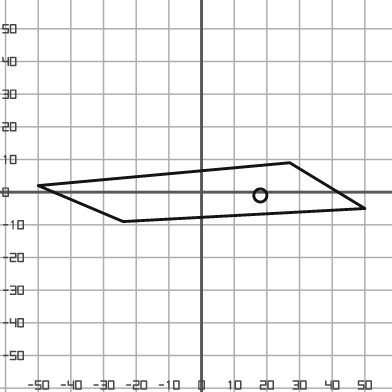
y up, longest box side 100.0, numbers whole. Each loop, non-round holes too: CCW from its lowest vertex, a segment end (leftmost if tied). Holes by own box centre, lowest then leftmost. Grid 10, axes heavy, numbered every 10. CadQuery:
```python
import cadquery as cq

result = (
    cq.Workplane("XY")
    .moveTo(-24.0, -9.0)
    .lineTo(50.0, -5.0)
    .lineTo(27.0, 9.0)
    .lineTo(-50.0, 2.0)
    .close()
    .moveTo(18.0, -1.0)
    .circle(2.0)
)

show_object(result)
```